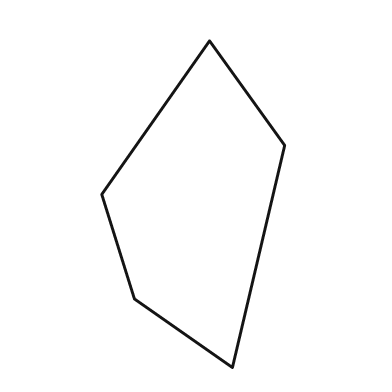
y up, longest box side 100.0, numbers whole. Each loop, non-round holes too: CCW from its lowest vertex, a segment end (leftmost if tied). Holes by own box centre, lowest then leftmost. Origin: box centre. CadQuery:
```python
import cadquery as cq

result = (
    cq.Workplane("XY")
    .moveTo(12.0, -50.0)
    .lineTo(28.0, 18.0)
    .lineTo(5.0, 50.0)
    .lineTo(-28.0, 3.0)
    .lineTo(-18.0, -29.0)
    .close()
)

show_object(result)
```